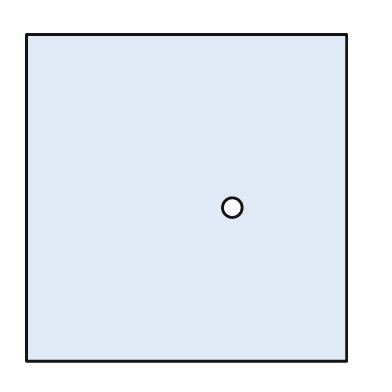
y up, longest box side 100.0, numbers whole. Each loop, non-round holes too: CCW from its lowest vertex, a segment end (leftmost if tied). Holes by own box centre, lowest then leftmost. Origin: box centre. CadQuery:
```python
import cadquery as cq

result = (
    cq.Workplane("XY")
    .moveTo(-49.0, -50.0)
    .lineTo(49.0, -50.0)
    .lineTo(49.0, 50.0)
    .lineTo(-49.0, 50.0)
    .close()
    .moveTo(14.0, -3.0)
    .circle(3.0)
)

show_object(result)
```